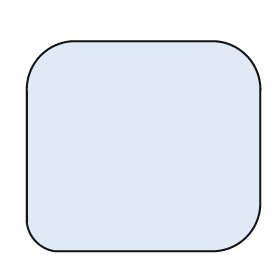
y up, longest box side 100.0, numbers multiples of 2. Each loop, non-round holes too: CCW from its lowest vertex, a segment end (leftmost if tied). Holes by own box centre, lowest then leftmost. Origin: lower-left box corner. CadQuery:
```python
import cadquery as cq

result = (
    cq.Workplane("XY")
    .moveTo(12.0, 0.0)
    .lineTo(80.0, 0.0)
    .threePointArc((94.0, 6.0), (100.0, 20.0))
    .lineTo(100.0, 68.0)
    .threePointArc((94.0, 84.0), (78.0, 90.0))
    .lineTo(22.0, 90.0)
    .threePointArc((6.0, 84.0), (0.0, 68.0))
    .lineTo(0.0, 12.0)
    .threePointArc((4.0, 4.0), (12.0, 0.0))
    .close()
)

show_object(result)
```